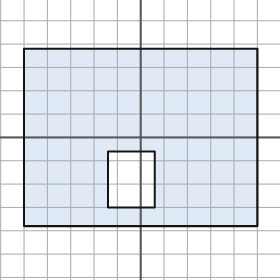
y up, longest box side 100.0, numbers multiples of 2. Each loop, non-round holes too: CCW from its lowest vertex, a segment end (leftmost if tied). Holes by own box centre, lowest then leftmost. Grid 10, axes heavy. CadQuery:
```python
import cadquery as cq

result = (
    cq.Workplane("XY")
    .moveTo(-50.0, -38.0)
    .lineTo(50.0, -38.0)
    .lineTo(50.0, 38.0)
    .lineTo(-50.0, 38.0)
    .close()
    .moveTo(-14.0, -30.0)
    .lineTo(6.0, -30.0)
    .lineTo(6.0, -6.0)
    .lineTo(-14.0, -6.0)
    .close()
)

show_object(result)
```